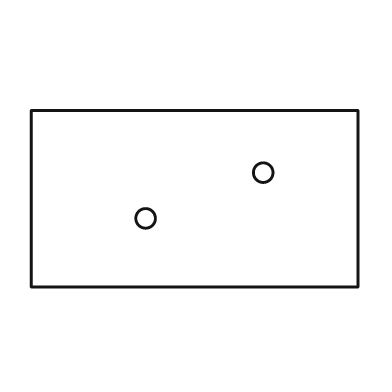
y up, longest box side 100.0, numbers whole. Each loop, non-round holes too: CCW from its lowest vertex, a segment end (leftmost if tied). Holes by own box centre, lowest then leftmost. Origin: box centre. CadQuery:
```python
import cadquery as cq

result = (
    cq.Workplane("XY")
    .moveTo(-50.0, -27.0)
    .lineTo(50.0, -27.0)
    .lineTo(50.0, 27.0)
    .lineTo(-50.0, 27.0)
    .close()
    .moveTo(-15.0, -6.0)
    .circle(3.0)
    .moveTo(21.0, 8.0)
    .circle(3.0)
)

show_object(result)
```